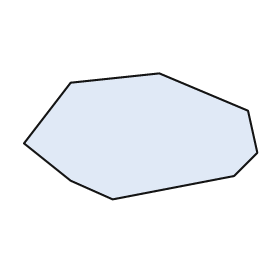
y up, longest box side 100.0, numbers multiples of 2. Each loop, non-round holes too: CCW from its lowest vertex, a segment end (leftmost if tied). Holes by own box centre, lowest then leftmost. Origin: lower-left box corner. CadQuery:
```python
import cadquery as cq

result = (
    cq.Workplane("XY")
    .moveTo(38.0, 0.0)
    .lineTo(90.0, 10.0)
    .lineTo(100.0, 20.0)
    .lineTo(96.0, 38.0)
    .lineTo(58.0, 54.0)
    .lineTo(20.0, 50.0)
    .lineTo(0.0, 24.0)
    .lineTo(20.0, 8.0)
    .close()
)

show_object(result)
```